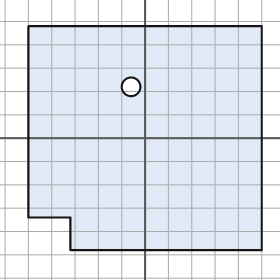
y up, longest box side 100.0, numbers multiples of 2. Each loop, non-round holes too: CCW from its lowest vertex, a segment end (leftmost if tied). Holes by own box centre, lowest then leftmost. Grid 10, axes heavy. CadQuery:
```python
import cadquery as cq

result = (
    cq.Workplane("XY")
    .moveTo(-32.0, -48.0)
    .lineTo(50.0, -48.0)
    .lineTo(50.0, 48.0)
    .lineTo(-50.0, 48.0)
    .lineTo(-50.0, -34.0)
    .lineTo(-32.0, -34.0)
    .close()
    .moveTo(-6.0, 22.0)
    .circle(4.0)
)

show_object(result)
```